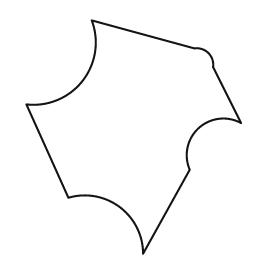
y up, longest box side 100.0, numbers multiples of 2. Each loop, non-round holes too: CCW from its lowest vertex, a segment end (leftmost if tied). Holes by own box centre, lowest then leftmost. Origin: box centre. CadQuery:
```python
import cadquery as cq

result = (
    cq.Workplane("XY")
    .moveTo(4.0, -50.0)
    .lineTo(24.0, -14.0)
    .threePointArc((28.0, 4.0), (46.0, 6.0))
    .lineTo(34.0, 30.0)
    .threePointArc((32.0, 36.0), (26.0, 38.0))
    .lineTo(-18.0, 50.0)
    .threePointArc((-22.0, 24.0), (-46.0, 14.0))
    .lineTo(-28.0, -26.0)
    .threePointArc((-6.0, -30.0), (4.0, -50.0))
    .close()
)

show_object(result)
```